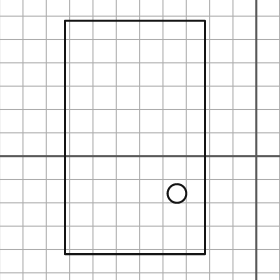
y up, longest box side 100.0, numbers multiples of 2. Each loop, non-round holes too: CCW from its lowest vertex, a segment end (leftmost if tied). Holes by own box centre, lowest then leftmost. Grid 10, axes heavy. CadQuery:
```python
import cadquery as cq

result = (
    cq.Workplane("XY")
    .moveTo(-82.0, -42.0)
    .lineTo(-22.0, -42.0)
    .lineTo(-22.0, 58.0)
    .lineTo(-82.0, 58.0)
    .close()
    .moveTo(-34.0, -16.0)
    .circle(4.0)
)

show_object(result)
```